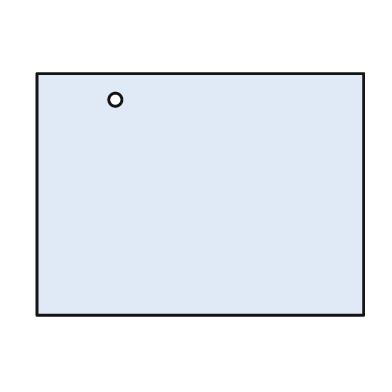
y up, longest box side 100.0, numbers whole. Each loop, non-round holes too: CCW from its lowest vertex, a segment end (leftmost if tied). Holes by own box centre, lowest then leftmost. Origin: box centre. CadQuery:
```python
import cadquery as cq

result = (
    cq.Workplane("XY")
    .moveTo(-50.0, -37.0)
    .lineTo(50.0, -37.0)
    .lineTo(50.0, 37.0)
    .lineTo(-50.0, 37.0)
    .close()
    .moveTo(-26.0, 29.0)
    .circle(2.0)
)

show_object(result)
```